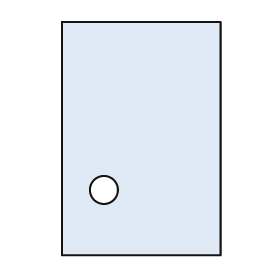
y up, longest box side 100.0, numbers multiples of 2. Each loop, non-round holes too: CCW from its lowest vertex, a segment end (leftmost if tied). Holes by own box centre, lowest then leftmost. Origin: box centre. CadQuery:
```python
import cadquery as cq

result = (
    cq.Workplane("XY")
    .moveTo(-34.0, -50.0)
    .lineTo(34.0, -50.0)
    .lineTo(34.0, 50.0)
    .lineTo(-34.0, 50.0)
    .close()
    .moveTo(-16.0, -22.0)
    .circle(6.0)
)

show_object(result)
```